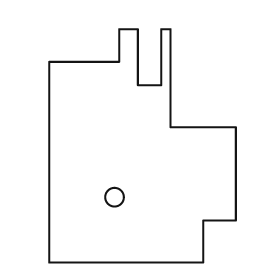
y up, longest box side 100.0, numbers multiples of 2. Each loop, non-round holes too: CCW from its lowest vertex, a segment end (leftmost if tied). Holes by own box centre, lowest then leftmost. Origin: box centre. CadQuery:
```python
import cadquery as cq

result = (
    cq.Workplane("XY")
    .moveTo(-40.0, -50.0)
    .lineTo(26.0, -50.0)
    .lineTo(26.0, -32.0)
    .lineTo(40.0, -32.0)
    .lineTo(40.0, 8.0)
    .lineTo(12.0, 8.0)
    .lineTo(12.0, 50.0)
    .lineTo(8.0, 50.0)
    .lineTo(8.0, 26.0)
    .lineTo(-2.0, 26.0)
    .lineTo(-2.0, 50.0)
    .lineTo(-10.0, 50.0)
    .lineTo(-10.0, 36.0)
    .lineTo(-40.0, 36.0)
    .close()
    .moveTo(-12.0, -22.0)
    .circle(4.0)
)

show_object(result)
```